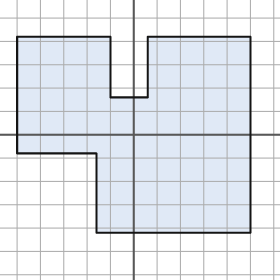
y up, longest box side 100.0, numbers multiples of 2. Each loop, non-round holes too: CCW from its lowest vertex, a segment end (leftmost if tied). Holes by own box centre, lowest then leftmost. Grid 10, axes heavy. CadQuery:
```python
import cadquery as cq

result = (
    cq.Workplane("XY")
    .moveTo(-16.0, -42.0)
    .lineTo(50.0, -42.0)
    .lineTo(50.0, 42.0)
    .lineTo(6.0, 42.0)
    .lineTo(6.0, 16.0)
    .lineTo(-10.0, 16.0)
    .lineTo(-10.0, 42.0)
    .lineTo(-50.0, 42.0)
    .lineTo(-50.0, -8.0)
    .lineTo(-16.0, -8.0)
    .close()
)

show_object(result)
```